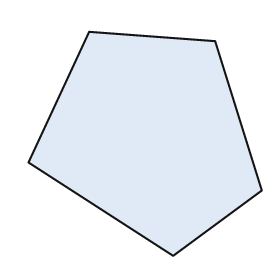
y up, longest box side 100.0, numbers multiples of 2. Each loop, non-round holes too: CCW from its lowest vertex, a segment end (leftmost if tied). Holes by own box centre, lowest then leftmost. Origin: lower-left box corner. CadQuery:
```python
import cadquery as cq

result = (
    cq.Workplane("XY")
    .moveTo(62.0, 0.0)
    .lineTo(100.0, 28.0)
    .lineTo(80.0, 92.0)
    .lineTo(26.0, 96.0)
    .lineTo(0.0, 40.0)
    .close()
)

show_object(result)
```